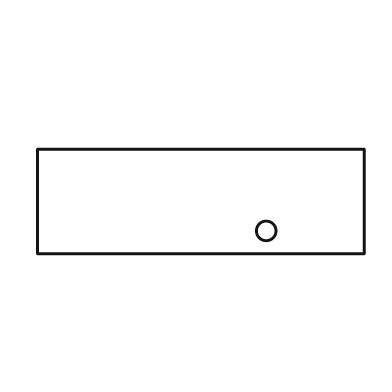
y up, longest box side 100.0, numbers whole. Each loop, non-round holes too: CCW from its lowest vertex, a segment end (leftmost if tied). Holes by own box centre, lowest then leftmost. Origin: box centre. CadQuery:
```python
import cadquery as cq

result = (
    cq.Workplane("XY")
    .moveTo(-50.0, -16.0)
    .lineTo(50.0, -16.0)
    .lineTo(50.0, 16.0)
    .lineTo(-50.0, 16.0)
    .close()
    .moveTo(20.0, -9.0)
    .circle(3.0)
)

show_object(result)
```